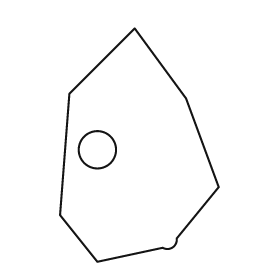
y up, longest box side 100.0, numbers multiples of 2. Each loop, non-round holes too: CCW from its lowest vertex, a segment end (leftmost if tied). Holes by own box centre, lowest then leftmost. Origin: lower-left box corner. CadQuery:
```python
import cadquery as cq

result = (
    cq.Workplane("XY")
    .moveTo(16.0, 0.0)
    .lineTo(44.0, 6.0)
    .threePointArc((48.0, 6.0), (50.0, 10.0))
    .lineTo(68.0, 32.0)
    .lineTo(54.0, 70.0)
    .lineTo(32.0, 100.0)
    .lineTo(4.0, 72.0)
    .lineTo(0.0, 20.0)
    .close()
    .moveTo(16.0, 48.0)
    .circle(8.0)
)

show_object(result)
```